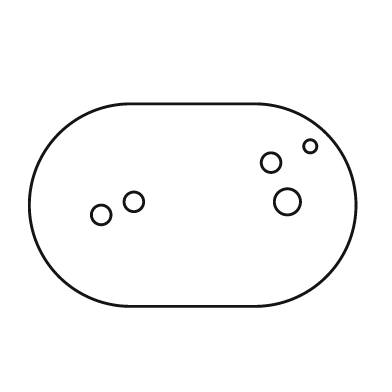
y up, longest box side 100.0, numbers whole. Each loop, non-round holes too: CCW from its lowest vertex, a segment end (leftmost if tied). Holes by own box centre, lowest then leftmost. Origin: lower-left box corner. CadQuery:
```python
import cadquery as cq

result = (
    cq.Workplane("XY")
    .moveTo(31.0, 0.0)
    .lineTo(69.0, 0.0)
    .threePointArc((100.0, 31.0), (69.0, 62.0))
    .lineTo(31.0, 62.0)
    .threePointArc((0.0, 31.0), (31.0, 0.0))
    .close()
    .moveTo(22.0, 28.0)
    .circle(3.0)
    .moveTo(32.0, 32.0)
    .circle(3.0)
    .moveTo(79.0, 32.0)
    .circle(4.0)
    .moveTo(74.0, 44.0)
    .circle(3.0)
    .moveTo(86.0, 49.0)
    .circle(2.0)
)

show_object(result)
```